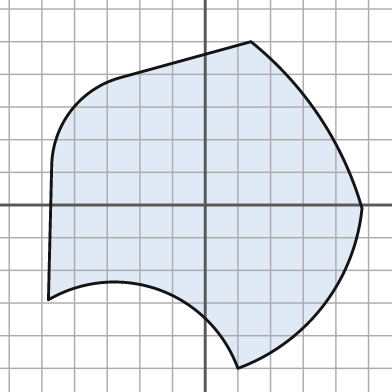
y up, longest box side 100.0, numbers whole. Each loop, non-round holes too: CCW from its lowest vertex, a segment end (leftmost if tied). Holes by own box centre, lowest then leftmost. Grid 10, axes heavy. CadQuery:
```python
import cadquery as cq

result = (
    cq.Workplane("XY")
    .moveTo(10.0, -50.0)
    .threePointArc((36.0, -31.0), (48.0, -1.0))
    .threePointArc((35.0, 27.0), (14.0, 50.0))
    .lineTo(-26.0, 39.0)
    .threePointArc((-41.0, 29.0), (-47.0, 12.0))
    .lineTo(-48.0, -29.0)
    .threePointArc((-14.0, -26.0), (10.0, -50.0))
    .close()
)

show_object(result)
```